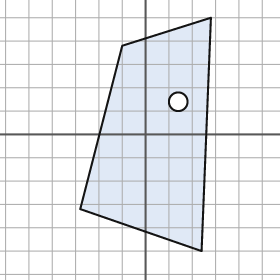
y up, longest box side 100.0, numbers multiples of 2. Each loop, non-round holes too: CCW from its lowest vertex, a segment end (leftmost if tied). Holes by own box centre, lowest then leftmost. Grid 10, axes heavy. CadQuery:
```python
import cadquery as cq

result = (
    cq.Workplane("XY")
    .moveTo(24.0, -50.0)
    .lineTo(28.0, 50.0)
    .lineTo(-10.0, 38.0)
    .lineTo(-28.0, -32.0)
    .close()
    .moveTo(14.0, 14.0)
    .circle(4.0)
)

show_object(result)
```